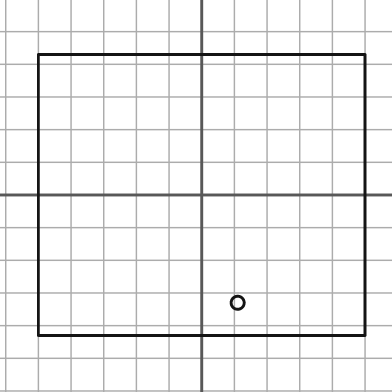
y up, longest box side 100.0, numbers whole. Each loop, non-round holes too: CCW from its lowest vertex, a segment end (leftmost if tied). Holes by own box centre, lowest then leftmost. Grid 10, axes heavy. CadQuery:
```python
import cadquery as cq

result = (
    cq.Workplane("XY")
    .moveTo(-50.0, -43.0)
    .lineTo(50.0, -43.0)
    .lineTo(50.0, 43.0)
    .lineTo(-50.0, 43.0)
    .close()
    .moveTo(11.0, -33.0)
    .circle(2.0)
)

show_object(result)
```